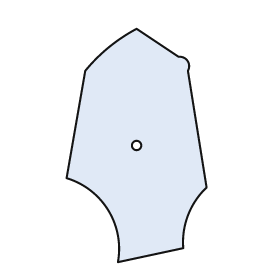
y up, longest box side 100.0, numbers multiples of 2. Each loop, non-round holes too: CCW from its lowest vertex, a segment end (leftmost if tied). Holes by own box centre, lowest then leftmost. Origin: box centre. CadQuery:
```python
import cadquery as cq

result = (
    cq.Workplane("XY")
    .moveTo(-8.0, -50.0)
    .lineTo(20.0, -44.0)
    .threePointArc((22.0, -30.0), (30.0, -18.0))
    .lineTo(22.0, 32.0)
    .threePointArc((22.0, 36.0), (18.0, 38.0))
    .lineTo(0.0, 50.0)
    .threePointArc((-12.0, 42.0), (-22.0, 32.0))
    .lineTo(-30.0, -14.0)
    .threePointArc((-12.0, -28.0), (-8.0, -50.0))
    .close()
    .moveTo(0.0, 0.0)
    .circle(2.0)
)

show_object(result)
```